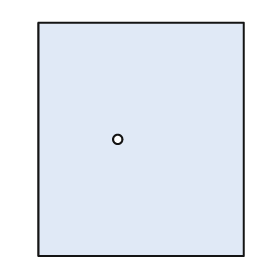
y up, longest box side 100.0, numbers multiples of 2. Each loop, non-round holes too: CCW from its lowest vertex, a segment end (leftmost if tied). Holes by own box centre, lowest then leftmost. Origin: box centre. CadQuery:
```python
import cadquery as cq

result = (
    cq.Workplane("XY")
    .moveTo(-44.0, -50.0)
    .lineTo(44.0, -50.0)
    .lineTo(44.0, 50.0)
    .lineTo(-44.0, 50.0)
    .close()
    .moveTo(-10.0, 0.0)
    .circle(2.0)
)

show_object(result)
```